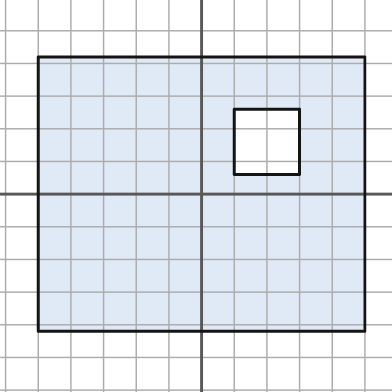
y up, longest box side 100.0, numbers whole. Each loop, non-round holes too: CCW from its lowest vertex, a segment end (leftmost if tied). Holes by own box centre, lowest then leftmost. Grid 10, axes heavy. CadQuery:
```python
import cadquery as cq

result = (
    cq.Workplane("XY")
    .moveTo(-50.0, -42.0)
    .lineTo(50.0, -42.0)
    .lineTo(50.0, 42.0)
    .lineTo(-50.0, 42.0)
    .close()
    .moveTo(10.0, 6.0)
    .lineTo(30.0, 6.0)
    .lineTo(30.0, 26.0)
    .lineTo(10.0, 26.0)
    .close()
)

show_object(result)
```